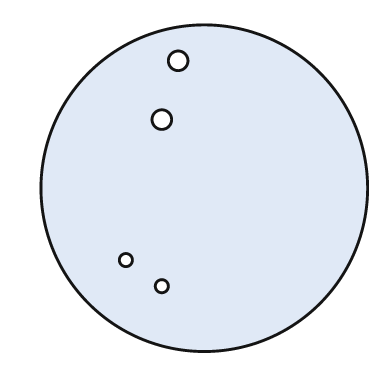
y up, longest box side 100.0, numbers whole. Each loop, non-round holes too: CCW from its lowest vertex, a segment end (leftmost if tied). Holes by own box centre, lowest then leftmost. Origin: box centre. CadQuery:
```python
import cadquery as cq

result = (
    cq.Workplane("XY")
    .moveTo(0.0, 0.0)
    .circle(50.0)
    .moveTo(-13.0, -30.0)
    .circle(2.0)
    .moveTo(-24.0, -22.0)
    .circle(2.0)
    .moveTo(-13.0, 21.0)
    .circle(3.0)
    .moveTo(-8.0, 39.0)
    .circle(3.0)
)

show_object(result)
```